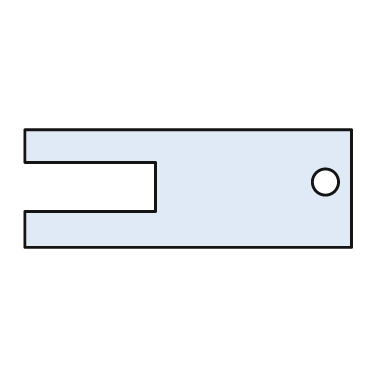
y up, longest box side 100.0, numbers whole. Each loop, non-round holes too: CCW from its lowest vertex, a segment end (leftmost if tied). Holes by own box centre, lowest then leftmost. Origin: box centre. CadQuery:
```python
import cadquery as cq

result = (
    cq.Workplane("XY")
    .moveTo(-50.0, -18.0)
    .lineTo(50.0, -18.0)
    .lineTo(50.0, 18.0)
    .lineTo(-50.0, 18.0)
    .lineTo(-50.0, 8.0)
    .lineTo(-10.0, 8.0)
    .lineTo(-10.0, -7.0)
    .lineTo(-50.0, -7.0)
    .close()
    .moveTo(42.0, 2.0)
    .circle(4.0)
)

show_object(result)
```